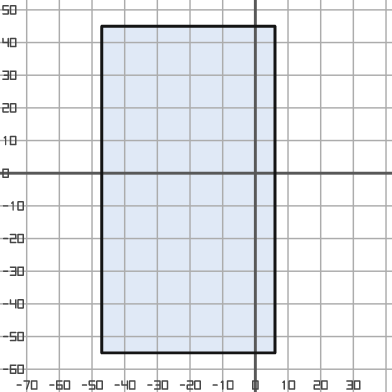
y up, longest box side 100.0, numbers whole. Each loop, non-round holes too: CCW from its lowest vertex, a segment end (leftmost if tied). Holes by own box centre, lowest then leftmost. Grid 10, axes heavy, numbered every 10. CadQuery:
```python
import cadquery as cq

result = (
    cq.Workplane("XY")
    .moveTo(-47.0, -55.0)
    .lineTo(6.0, -55.0)
    .lineTo(6.0, 45.0)
    .lineTo(-47.0, 45.0)
    .close()
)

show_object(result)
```